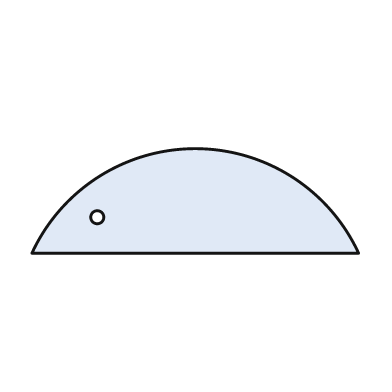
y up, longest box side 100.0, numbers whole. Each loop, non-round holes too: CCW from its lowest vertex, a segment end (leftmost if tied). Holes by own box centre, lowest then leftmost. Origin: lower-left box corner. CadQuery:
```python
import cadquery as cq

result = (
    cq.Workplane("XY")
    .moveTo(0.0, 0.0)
    .lineTo(100.0, 0.0)
    .threePointArc((50.0, 32.0), (0.0, 0.0))
    .close()
    .moveTo(20.0, 11.0)
    .circle(2.0)
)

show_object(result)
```